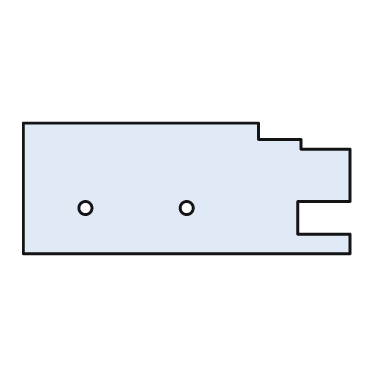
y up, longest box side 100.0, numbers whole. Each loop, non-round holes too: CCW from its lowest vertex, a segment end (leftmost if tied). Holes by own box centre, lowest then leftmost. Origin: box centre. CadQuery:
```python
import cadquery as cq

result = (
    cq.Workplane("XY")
    .moveTo(-50.0, -20.0)
    .lineTo(50.0, -20.0)
    .lineTo(50.0, -14.0)
    .lineTo(34.0, -14.0)
    .lineTo(34.0, -4.0)
    .lineTo(50.0, -4.0)
    .lineTo(50.0, 12.0)
    .lineTo(35.0, 12.0)
    .lineTo(35.0, 15.0)
    .lineTo(22.0, 15.0)
    .lineTo(22.0, 20.0)
    .lineTo(-50.0, 20.0)
    .close()
    .moveTo(-31.0, -6.0)
    .circle(2.0)
    .moveTo(0.0, -6.0)
    .circle(2.0)
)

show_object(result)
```